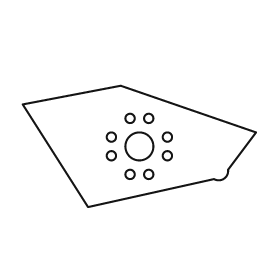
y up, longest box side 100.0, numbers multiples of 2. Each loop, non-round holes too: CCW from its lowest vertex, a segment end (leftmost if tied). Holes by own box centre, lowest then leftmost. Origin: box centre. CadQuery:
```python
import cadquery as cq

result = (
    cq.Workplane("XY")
    .moveTo(-22.0, -26.0)
    .lineTo(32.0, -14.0)
    .threePointArc((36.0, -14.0), (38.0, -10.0))
    .lineTo(50.0, 6.0)
    .lineTo(-8.0, 26.0)
    .lineTo(-50.0, 18.0)
    .close()
    .moveTo(-4.0, -12.0)
    .circle(2.0)
    .moveTo(4.0, -12.0)
    .circle(2.0)
    .moveTo(-12.0, -4.0)
    .circle(2.0)
    .moveTo(12.0, -4.0)
    .circle(2.0)
    .moveTo(0.0, 0.0)
    .circle(6.0)
    .moveTo(-12.0, 4.0)
    .circle(2.0)
    .moveTo(12.0, 4.0)
    .circle(2.0)
    .moveTo(-4.0, 12.0)
    .circle(2.0)
    .moveTo(4.0, 12.0)
    .circle(2.0)
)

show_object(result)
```